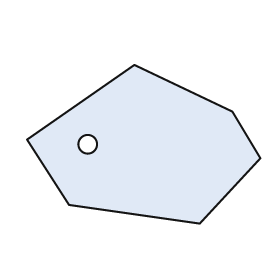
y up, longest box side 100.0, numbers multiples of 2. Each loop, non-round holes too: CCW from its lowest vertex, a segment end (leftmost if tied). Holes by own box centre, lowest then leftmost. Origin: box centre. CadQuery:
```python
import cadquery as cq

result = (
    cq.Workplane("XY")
    .moveTo(24.0, -34.0)
    .lineTo(50.0, -6.0)
    .lineTo(38.0, 14.0)
    .lineTo(-4.0, 34.0)
    .lineTo(-50.0, 2.0)
    .lineTo(-32.0, -26.0)
    .close()
    .moveTo(-24.0, 0.0)
    .circle(4.0)
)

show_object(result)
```